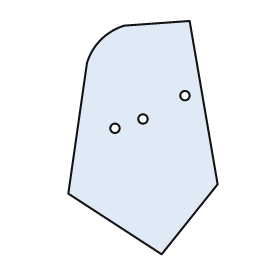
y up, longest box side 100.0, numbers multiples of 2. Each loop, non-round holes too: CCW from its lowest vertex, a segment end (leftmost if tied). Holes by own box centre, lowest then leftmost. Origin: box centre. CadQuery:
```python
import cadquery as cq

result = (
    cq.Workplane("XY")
    .moveTo(8.0, -50.0)
    .lineTo(32.0, -20.0)
    .lineTo(20.0, 50.0)
    .lineTo(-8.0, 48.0)
    .threePointArc((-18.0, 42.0), (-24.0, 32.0))
    .lineTo(-32.0, -24.0)
    .close()
    .moveTo(-12.0, 4.0)
    .circle(2.0)
    .moveTo(0.0, 8.0)
    .circle(2.0)
    .moveTo(18.0, 18.0)
    .circle(2.0)
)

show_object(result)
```